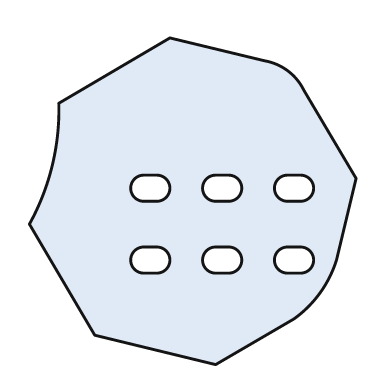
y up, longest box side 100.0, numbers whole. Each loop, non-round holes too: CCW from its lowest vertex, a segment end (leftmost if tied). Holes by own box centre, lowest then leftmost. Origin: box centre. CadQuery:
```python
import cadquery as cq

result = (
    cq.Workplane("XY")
    .moveTo(7.0, -50.0)
    .lineTo(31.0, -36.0)
    .threePointArc((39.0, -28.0), (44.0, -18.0))
    .lineTo(50.0, 7.0)
    .lineTo(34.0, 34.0)
    .threePointArc((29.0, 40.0), (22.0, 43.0))
    .lineTo(-7.0, 50.0)
    .lineTo(-41.0, 30.0)
    .threePointArc((-43.0, 11.0), (-50.0, -7.0))
    .lineTo(-30.0, -41.0)
    .close()
    .moveTo(-15.0, -22.0)
    .lineTo(-11.0, -22.0)
    .threePointArc((-7.0, -18.0), (-11.0, -14.0))
    .lineTo(-15.0, -14.0)
    .threePointArc((-19.0, -18.0), (-15.0, -22.0))
    .close()
    .moveTo(7.0, -22.0)
    .lineTo(11.0, -22.0)
    .threePointArc((15.0, -18.0), (11.0, -14.0))
    .lineTo(7.0, -14.0)
    .threePointArc((3.0, -18.0), (7.0, -22.0))
    .close()
    .moveTo(29.0, -22.0)
    .lineTo(33.0, -22.0)
    .threePointArc((37.0, -18.0), (33.0, -14.0))
    .lineTo(29.0, -14.0)
    .threePointArc((25.0, -18.0), (29.0, -22.0))
    .close()
    .moveTo(-15.0, 0.0)
    .lineTo(-11.0, 0.0)
    .threePointArc((-7.0, 4.0), (-11.0, 8.0))
    .lineTo(-15.0, 8.0)
    .threePointArc((-19.0, 4.0), (-15.0, 0.0))
    .close()
    .moveTo(7.0, 0.0)
    .lineTo(11.0, 0.0)
    .threePointArc((15.0, 4.0), (11.0, 8.0))
    .lineTo(7.0, 8.0)
    .threePointArc((3.0, 4.0), (7.0, 0.0))
    .close()
    .moveTo(29.0, 0.0)
    .lineTo(33.0, 0.0)
    .threePointArc((37.0, 4.0), (33.0, 8.0))
    .lineTo(29.0, 8.0)
    .threePointArc((25.0, 4.0), (29.0, 0.0))
    .close()
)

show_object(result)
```